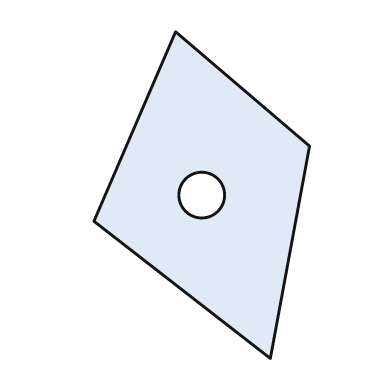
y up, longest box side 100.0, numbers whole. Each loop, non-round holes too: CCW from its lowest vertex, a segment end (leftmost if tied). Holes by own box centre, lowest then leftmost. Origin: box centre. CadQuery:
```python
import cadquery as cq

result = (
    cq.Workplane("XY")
    .moveTo(21.0, -50.0)
    .lineTo(33.0, 15.0)
    .lineTo(-8.0, 50.0)
    .lineTo(-33.0, -8.0)
    .close()
    .moveTo(0.0, 0.0)
    .circle(7.0)
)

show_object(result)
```